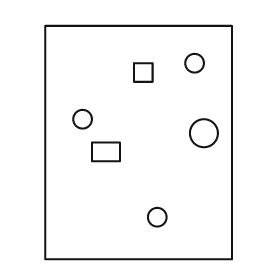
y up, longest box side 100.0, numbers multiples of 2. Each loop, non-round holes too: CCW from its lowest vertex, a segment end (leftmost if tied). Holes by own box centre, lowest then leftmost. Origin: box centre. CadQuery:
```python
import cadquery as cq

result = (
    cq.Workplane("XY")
    .moveTo(-40.0, -50.0)
    .lineTo(40.0, -50.0)
    .lineTo(40.0, 50.0)
    .lineTo(-40.0, 50.0)
    .close()
    .moveTo(8.0, -32.0)
    .circle(4.0)
    .moveTo(-20.0, -8.0)
    .lineTo(-8.0, -8.0)
    .lineTo(-8.0, 0.0)
    .lineTo(-20.0, 0.0)
    .close()
    .moveTo(28.0, 4.0)
    .circle(6.0)
    .moveTo(-24.0, 10.0)
    .circle(4.0)
    .moveTo(-2.0, 26.0)
    .lineTo(6.0, 26.0)
    .lineTo(6.0, 34.0)
    .lineTo(-2.0, 34.0)
    .close()
    .moveTo(24.0, 34.0)
    .circle(4.0)
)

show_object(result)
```